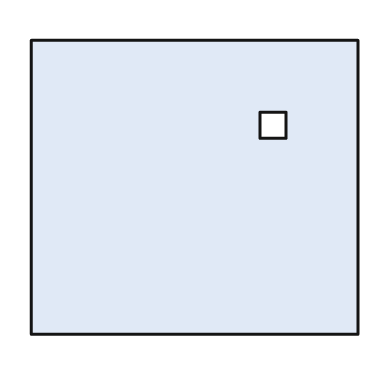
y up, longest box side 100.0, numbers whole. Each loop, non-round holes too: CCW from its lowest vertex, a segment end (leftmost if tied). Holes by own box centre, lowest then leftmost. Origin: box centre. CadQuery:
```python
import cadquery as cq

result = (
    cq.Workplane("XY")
    .moveTo(-50.0, -45.0)
    .lineTo(50.0, -45.0)
    .lineTo(50.0, 45.0)
    .lineTo(-50.0, 45.0)
    .close()
    .moveTo(20.0, 15.0)
    .lineTo(28.0, 15.0)
    .lineTo(28.0, 23.0)
    .lineTo(20.0, 23.0)
    .close()
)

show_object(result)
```